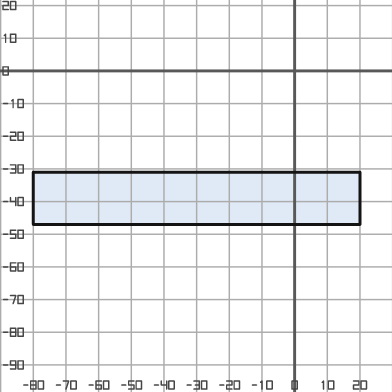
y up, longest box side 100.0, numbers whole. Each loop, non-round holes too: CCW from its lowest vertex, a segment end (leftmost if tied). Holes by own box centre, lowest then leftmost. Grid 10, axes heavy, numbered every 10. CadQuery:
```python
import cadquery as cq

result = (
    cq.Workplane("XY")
    .moveTo(-80.0, -47.0)
    .lineTo(20.0, -47.0)
    .lineTo(20.0, -31.0)
    .lineTo(-80.0, -31.0)
    .close()
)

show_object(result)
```